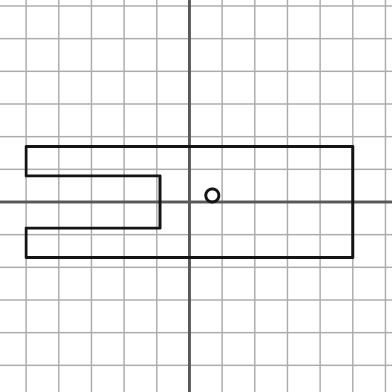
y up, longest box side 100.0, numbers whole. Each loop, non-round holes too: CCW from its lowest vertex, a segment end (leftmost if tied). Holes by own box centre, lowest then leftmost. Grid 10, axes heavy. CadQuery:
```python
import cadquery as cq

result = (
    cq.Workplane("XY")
    .moveTo(-50.0, -17.0)
    .lineTo(50.0, -17.0)
    .lineTo(50.0, 17.0)
    .lineTo(-50.0, 17.0)
    .lineTo(-50.0, 8.0)
    .lineTo(-9.0, 8.0)
    .lineTo(-9.0, -8.0)
    .lineTo(-50.0, -8.0)
    .close()
    .moveTo(7.0, 2.0)
    .circle(2.0)
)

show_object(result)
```